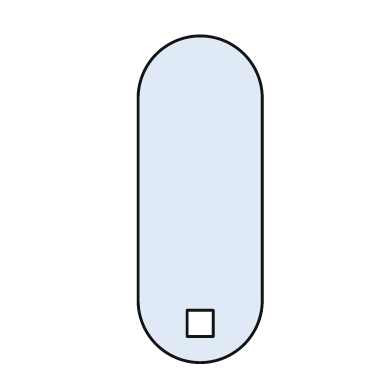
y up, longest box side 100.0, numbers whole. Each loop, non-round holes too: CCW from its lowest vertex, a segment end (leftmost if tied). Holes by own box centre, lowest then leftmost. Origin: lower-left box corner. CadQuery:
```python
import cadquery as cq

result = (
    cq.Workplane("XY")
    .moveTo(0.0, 19.0)
    .threePointArc((19.0, 0.0), (38.0, 19.0))
    .lineTo(38.0, 81.0)
    .threePointArc((19.0, 100.0), (0.0, 81.0))
    .close()
    .moveTo(15.0, 8.0)
    .lineTo(23.0, 8.0)
    .lineTo(23.0, 16.0)
    .lineTo(15.0, 16.0)
    .close()
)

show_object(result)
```